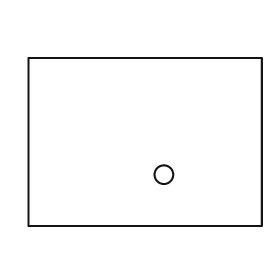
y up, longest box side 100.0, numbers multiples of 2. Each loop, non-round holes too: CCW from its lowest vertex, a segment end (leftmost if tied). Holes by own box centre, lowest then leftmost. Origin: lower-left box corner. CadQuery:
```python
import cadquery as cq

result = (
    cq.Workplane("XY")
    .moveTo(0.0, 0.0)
    .lineTo(100.0, 0.0)
    .lineTo(100.0, 72.0)
    .lineTo(0.0, 72.0)
    .close()
    .moveTo(58.0, 22.0)
    .circle(4.0)
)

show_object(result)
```